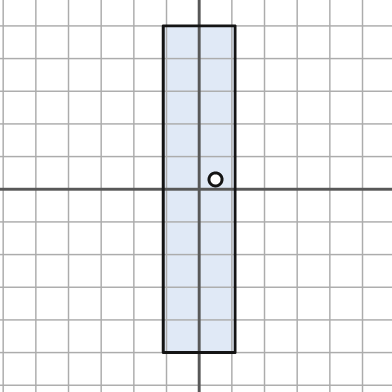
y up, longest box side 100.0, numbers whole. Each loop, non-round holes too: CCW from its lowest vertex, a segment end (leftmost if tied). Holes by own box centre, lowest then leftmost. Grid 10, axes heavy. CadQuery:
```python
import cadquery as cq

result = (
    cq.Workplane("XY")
    .moveTo(-11.0, -50.0)
    .lineTo(11.0, -50.0)
    .lineTo(11.0, 50.0)
    .lineTo(-11.0, 50.0)
    .close()
    .moveTo(5.0, 3.0)
    .circle(2.0)
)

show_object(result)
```